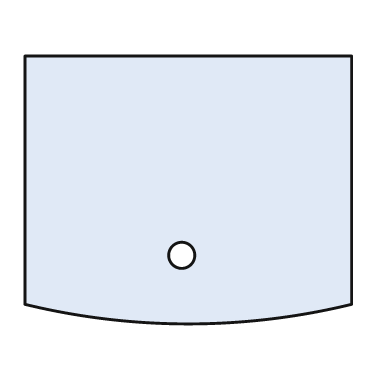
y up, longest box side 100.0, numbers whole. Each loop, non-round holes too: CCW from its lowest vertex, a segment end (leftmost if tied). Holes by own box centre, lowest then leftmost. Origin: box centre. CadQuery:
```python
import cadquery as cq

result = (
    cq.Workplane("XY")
    .moveTo(-50.0, -35.0)
    .threePointArc((0.0, -41.0), (50.0, -35.0))
    .lineTo(50.0, 41.0)
    .lineTo(-50.0, 41.0)
    .close()
    .moveTo(-2.0, -20.0)
    .circle(4.0)
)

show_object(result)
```